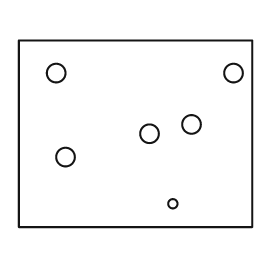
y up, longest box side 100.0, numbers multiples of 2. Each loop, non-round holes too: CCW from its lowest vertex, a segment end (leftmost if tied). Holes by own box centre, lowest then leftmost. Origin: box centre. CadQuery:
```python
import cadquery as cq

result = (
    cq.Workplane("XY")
    .moveTo(-50.0, -40.0)
    .lineTo(50.0, -40.0)
    .lineTo(50.0, 40.0)
    .lineTo(-50.0, 40.0)
    .close()
    .moveTo(16.0, -30.0)
    .circle(2.0)
    .moveTo(-30.0, -10.0)
    .circle(4.0)
    .moveTo(6.0, 0.0)
    .circle(4.0)
    .moveTo(24.0, 4.0)
    .circle(4.0)
    .moveTo(-34.0, 26.0)
    .circle(4.0)
    .moveTo(42.0, 26.0)
    .circle(4.0)
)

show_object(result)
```